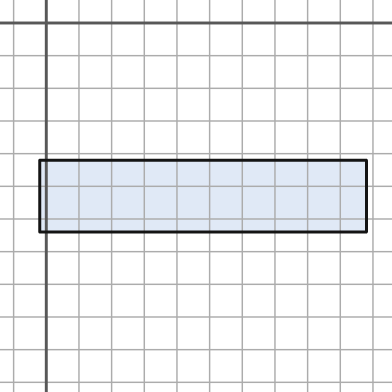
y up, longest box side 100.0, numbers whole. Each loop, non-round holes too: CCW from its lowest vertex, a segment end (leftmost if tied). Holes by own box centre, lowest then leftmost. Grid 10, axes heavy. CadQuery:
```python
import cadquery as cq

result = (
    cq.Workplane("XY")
    .moveTo(-2.0, -64.0)
    .lineTo(98.0, -64.0)
    .lineTo(98.0, -42.0)
    .lineTo(-2.0, -42.0)
    .close()
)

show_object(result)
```